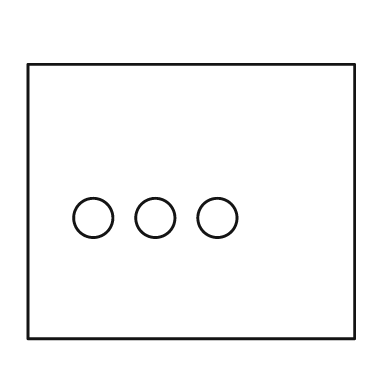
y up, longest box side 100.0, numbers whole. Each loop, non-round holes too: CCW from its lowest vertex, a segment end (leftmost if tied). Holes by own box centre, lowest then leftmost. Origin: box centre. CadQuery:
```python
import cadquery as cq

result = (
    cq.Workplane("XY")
    .moveTo(-50.0, -42.0)
    .lineTo(50.0, -42.0)
    .lineTo(50.0, 42.0)
    .lineTo(-50.0, 42.0)
    .close()
    .moveTo(-30.0, -5.0)
    .circle(6.0)
    .moveTo(-11.0, -5.0)
    .circle(6.0)
    .moveTo(8.0, -5.0)
    .circle(6.0)
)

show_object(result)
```